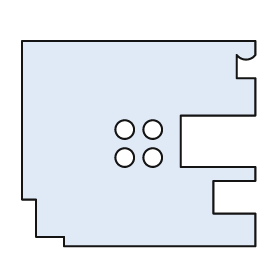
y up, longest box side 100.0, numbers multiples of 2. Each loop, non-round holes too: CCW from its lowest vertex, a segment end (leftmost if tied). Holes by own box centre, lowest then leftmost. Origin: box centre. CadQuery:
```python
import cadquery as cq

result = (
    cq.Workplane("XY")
    .moveTo(-32.0, -44.0)
    .lineTo(50.0, -44.0)
    .lineTo(50.0, -30.0)
    .lineTo(32.0, -30.0)
    .lineTo(32.0, -16.0)
    .lineTo(50.0, -16.0)
    .lineTo(50.0, -10.0)
    .lineTo(18.0, -10.0)
    .lineTo(18.0, 12.0)
    .lineTo(50.0, 12.0)
    .lineTo(50.0, 28.0)
    .lineTo(42.0, 28.0)
    .lineTo(42.0, 38.0)
    .threePointArc((46.0, 36.0), (50.0, 38.0))
    .lineTo(50.0, 44.0)
    .lineTo(-50.0, 44.0)
    .lineTo(-50.0, -24.0)
    .lineTo(-44.0, -24.0)
    .lineTo(-44.0, -40.0)
    .lineTo(-32.0, -40.0)
    .close()
    .moveTo(-6.0, -6.0)
    .circle(4.0)
    .moveTo(6.0, -6.0)
    .circle(4.0)
    .moveTo(-6.0, 6.0)
    .circle(4.0)
    .moveTo(6.0, 6.0)
    .circle(4.0)
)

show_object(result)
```